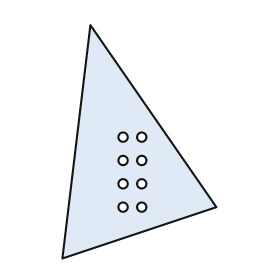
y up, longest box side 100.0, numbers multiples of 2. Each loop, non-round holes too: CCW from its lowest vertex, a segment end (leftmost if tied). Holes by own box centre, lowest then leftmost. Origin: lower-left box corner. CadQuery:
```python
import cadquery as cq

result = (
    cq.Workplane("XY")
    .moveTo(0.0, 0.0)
    .lineTo(66.0, 22.0)
    .lineTo(12.0, 100.0)
    .close()
    .moveTo(26.0, 22.0)
    .circle(2.0)
    .moveTo(34.0, 22.0)
    .circle(2.0)
    .moveTo(26.0, 32.0)
    .circle(2.0)
    .moveTo(34.0, 32.0)
    .circle(2.0)
    .moveTo(26.0, 42.0)
    .circle(2.0)
    .moveTo(34.0, 42.0)
    .circle(2.0)
    .moveTo(26.0, 52.0)
    .circle(2.0)
    .moveTo(34.0, 52.0)
    .circle(2.0)
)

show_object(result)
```